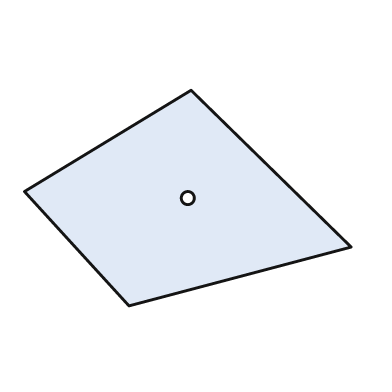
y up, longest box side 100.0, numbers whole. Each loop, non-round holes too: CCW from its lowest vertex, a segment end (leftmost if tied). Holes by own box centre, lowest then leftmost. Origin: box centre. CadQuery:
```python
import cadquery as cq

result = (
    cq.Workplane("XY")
    .moveTo(-18.0, -33.0)
    .lineTo(50.0, -15.0)
    .lineTo(1.0, 33.0)
    .lineTo(-50.0, 2.0)
    .close()
    .moveTo(0.0, 0.0)
    .circle(2.0)
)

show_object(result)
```